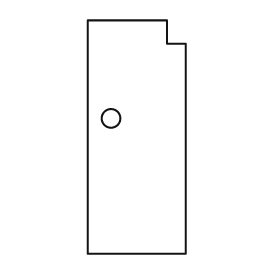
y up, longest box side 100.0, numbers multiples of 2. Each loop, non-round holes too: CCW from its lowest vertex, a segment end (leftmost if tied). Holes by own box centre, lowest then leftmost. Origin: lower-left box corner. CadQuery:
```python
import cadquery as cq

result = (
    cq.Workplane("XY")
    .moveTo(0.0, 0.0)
    .lineTo(42.0, 0.0)
    .lineTo(42.0, 90.0)
    .lineTo(34.0, 90.0)
    .lineTo(34.0, 100.0)
    .lineTo(0.0, 100.0)
    .close()
    .moveTo(10.0, 58.0)
    .circle(4.0)
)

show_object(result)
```